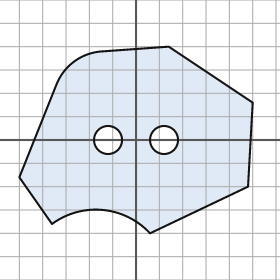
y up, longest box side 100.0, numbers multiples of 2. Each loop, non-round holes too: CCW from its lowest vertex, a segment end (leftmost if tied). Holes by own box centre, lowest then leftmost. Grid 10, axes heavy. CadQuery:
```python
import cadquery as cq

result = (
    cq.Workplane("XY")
    .moveTo(6.0, -40.0)
    .lineTo(48.0, -20.0)
    .lineTo(50.0, 16.0)
    .lineTo(14.0, 40.0)
    .lineTo(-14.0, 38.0)
    .threePointArc((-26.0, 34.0), (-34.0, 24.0))
    .lineTo(-50.0, -16.0)
    .lineTo(-36.0, -36.0)
    .threePointArc((-14.0, -30.0), (6.0, -40.0))
    .close()
    .moveTo(-12.0, 0.0)
    .circle(6.0)
    .moveTo(12.0, 0.0)
    .circle(6.0)
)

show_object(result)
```